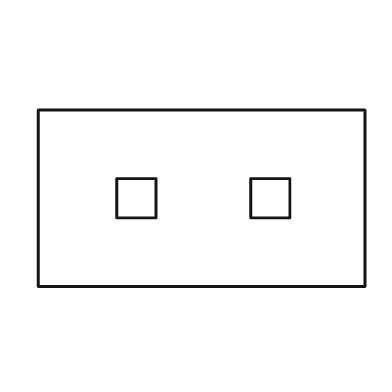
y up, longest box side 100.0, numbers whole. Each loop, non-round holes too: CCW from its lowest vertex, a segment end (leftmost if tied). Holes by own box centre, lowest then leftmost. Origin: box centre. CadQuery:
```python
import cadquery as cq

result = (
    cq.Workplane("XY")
    .moveTo(-50.0, -27.0)
    .lineTo(50.0, -27.0)
    .lineTo(50.0, 27.0)
    .lineTo(-50.0, 27.0)
    .close()
    .moveTo(-26.0, -6.0)
    .lineTo(-14.0, -6.0)
    .lineTo(-14.0, 6.0)
    .lineTo(-26.0, 6.0)
    .close()
    .moveTo(15.0, -6.0)
    .lineTo(27.0, -6.0)
    .lineTo(27.0, 6.0)
    .lineTo(15.0, 6.0)
    .close()
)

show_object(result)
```